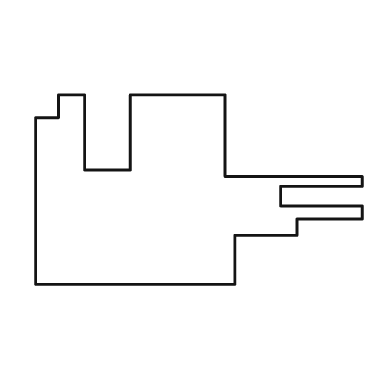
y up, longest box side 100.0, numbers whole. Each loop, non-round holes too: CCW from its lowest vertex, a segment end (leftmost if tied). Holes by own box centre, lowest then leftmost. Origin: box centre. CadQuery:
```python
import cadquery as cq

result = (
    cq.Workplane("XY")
    .moveTo(-50.0, -29.0)
    .lineTo(11.0, -29.0)
    .lineTo(11.0, -14.0)
    .lineTo(30.0, -14.0)
    .lineTo(30.0, -9.0)
    .lineTo(50.0, -9.0)
    .lineTo(50.0, -5.0)
    .lineTo(25.0, -5.0)
    .lineTo(25.0, 1.0)
    .lineTo(50.0, 1.0)
    .lineTo(50.0, 4.0)
    .lineTo(8.0, 4.0)
    .lineTo(8.0, 29.0)
    .lineTo(-21.0, 29.0)
    .lineTo(-21.0, 6.0)
    .lineTo(-35.0, 6.0)
    .lineTo(-35.0, 29.0)
    .lineTo(-43.0, 29.0)
    .lineTo(-43.0, 22.0)
    .lineTo(-50.0, 22.0)
    .close()
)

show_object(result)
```